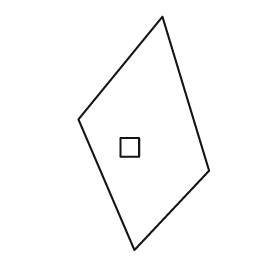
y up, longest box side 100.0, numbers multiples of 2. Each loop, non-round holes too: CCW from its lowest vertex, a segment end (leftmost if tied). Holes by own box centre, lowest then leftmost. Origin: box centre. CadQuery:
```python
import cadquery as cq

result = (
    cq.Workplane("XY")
    .moveTo(-4.0, -50.0)
    .lineTo(28.0, -16.0)
    .lineTo(8.0, 50.0)
    .lineTo(-28.0, 6.0)
    .close()
    .moveTo(-10.0, -10.0)
    .lineTo(-2.0, -10.0)
    .lineTo(-2.0, -2.0)
    .lineTo(-10.0, -2.0)
    .close()
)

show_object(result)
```